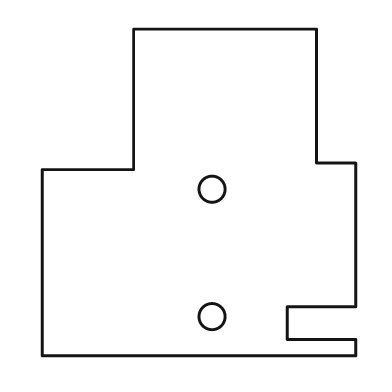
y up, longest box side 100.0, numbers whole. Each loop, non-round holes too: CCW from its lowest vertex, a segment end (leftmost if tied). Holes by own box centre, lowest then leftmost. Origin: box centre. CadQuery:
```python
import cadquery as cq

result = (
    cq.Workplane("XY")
    .moveTo(-48.0, -50.0)
    .lineTo(48.0, -50.0)
    .lineTo(48.0, -45.0)
    .lineTo(27.0, -45.0)
    .lineTo(27.0, -35.0)
    .lineTo(48.0, -35.0)
    .lineTo(48.0, 9.0)
    .lineTo(36.0, 9.0)
    .lineTo(36.0, 50.0)
    .lineTo(-20.0, 50.0)
    .lineTo(-20.0, 7.0)
    .lineTo(-48.0, 7.0)
    .close()
    .moveTo(4.0, -38.0)
    .circle(4.0)
    .moveTo(4.0, 1.0)
    .circle(4.0)
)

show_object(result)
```